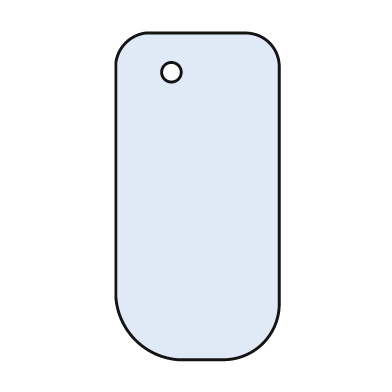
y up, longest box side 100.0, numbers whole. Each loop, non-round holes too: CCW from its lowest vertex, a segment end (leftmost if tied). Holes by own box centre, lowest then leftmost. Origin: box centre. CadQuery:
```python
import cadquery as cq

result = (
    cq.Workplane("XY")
    .moveTo(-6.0, -50.0)
    .lineTo(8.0, -50.0)
    .threePointArc((20.0, -45.0), (25.0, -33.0))
    .lineTo(25.0, 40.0)
    .threePointArc((22.0, 47.0), (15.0, 50.0))
    .lineTo(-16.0, 50.0)
    .threePointArc((-22.0, 47.0), (-25.0, 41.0))
    .lineTo(-25.0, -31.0)
    .threePointArc((-19.0, -44.0), (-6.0, -50.0))
    .close()
    .moveTo(-8.0, 38.0)
    .circle(3.0)
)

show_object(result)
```